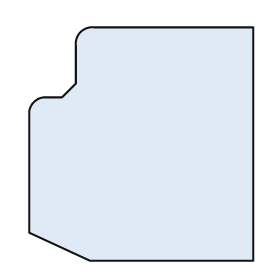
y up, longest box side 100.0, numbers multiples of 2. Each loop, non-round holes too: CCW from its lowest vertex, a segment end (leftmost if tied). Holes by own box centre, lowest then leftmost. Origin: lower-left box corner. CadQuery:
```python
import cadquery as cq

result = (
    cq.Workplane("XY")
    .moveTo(26.0, 0.0)
    .lineTo(96.0, 0.0)
    .lineTo(96.0, 100.0)
    .lineTo(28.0, 100.0)
    .threePointArc((22.0, 98.0), (20.0, 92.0))
    .lineTo(20.0, 76.0)
    .lineTo(14.0, 70.0)
    .lineTo(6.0, 70.0)
    .threePointArc((2.0, 68.0), (0.0, 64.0))
    .lineTo(0.0, 12.0)
    .close()
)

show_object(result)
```